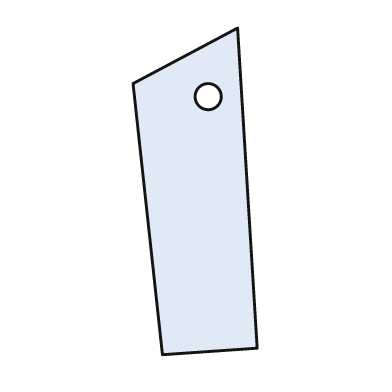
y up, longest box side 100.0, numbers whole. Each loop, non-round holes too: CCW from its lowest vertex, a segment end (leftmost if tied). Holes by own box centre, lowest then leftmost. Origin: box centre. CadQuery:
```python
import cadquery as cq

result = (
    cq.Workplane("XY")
    .moveTo(-10.0, -50.0)
    .lineTo(19.0, -48.0)
    .lineTo(13.0, 50.0)
    .lineTo(-19.0, 33.0)
    .close()
    .moveTo(4.0, 29.0)
    .circle(4.0)
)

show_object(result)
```